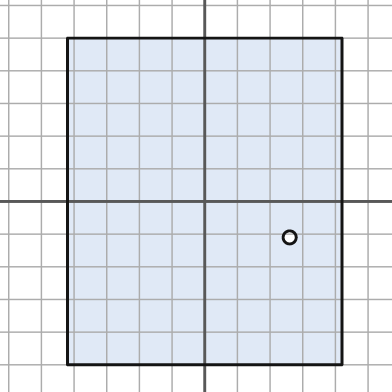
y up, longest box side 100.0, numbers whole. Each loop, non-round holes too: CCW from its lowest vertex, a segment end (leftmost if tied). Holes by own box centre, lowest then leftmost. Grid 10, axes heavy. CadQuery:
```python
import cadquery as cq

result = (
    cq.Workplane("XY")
    .moveTo(-42.0, -50.0)
    .lineTo(42.0, -50.0)
    .lineTo(42.0, 50.0)
    .lineTo(-42.0, 50.0)
    .close()
    .moveTo(26.0, -11.0)
    .circle(2.0)
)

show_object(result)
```